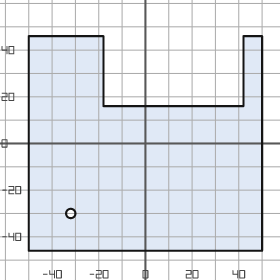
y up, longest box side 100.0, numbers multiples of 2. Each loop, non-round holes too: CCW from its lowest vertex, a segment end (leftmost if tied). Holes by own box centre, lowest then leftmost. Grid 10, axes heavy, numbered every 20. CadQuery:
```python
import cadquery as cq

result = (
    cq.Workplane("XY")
    .moveTo(-50.0, -46.0)
    .lineTo(50.0, -46.0)
    .lineTo(50.0, 46.0)
    .lineTo(42.0, 46.0)
    .lineTo(42.0, 16.0)
    .lineTo(-18.0, 16.0)
    .lineTo(-18.0, 46.0)
    .lineTo(-50.0, 46.0)
    .close()
    .moveTo(-32.0, -30.0)
    .circle(2.0)
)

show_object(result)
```